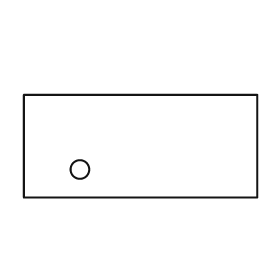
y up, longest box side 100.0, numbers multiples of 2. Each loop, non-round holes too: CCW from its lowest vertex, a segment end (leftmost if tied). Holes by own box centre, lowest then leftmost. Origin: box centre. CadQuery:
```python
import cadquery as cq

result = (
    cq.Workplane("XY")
    .moveTo(-50.0, -22.0)
    .lineTo(50.0, -22.0)
    .lineTo(50.0, 22.0)
    .lineTo(-50.0, 22.0)
    .close()
    .moveTo(-26.0, -10.0)
    .circle(4.0)
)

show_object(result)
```